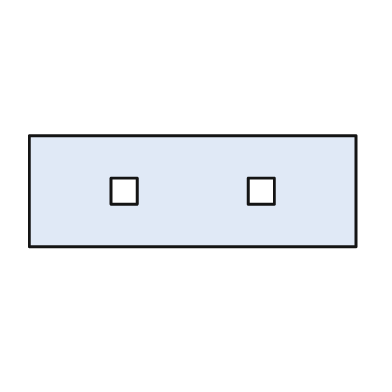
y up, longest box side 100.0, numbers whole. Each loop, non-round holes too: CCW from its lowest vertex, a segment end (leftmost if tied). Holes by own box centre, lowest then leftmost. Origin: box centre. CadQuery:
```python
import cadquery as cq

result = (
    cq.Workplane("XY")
    .moveTo(-50.0, -17.0)
    .lineTo(50.0, -17.0)
    .lineTo(50.0, 17.0)
    .lineTo(-50.0, 17.0)
    .close()
    .moveTo(-25.0, -4.0)
    .lineTo(-17.0, -4.0)
    .lineTo(-17.0, 4.0)
    .lineTo(-25.0, 4.0)
    .close()
    .moveTo(17.0, -4.0)
    .lineTo(25.0, -4.0)
    .lineTo(25.0, 4.0)
    .lineTo(17.0, 4.0)
    .close()
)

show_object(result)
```